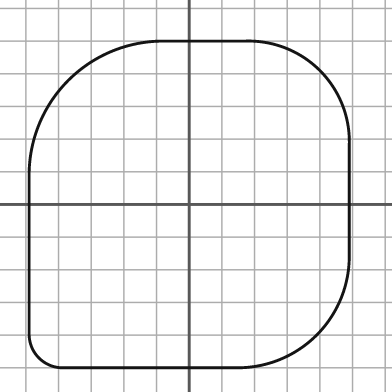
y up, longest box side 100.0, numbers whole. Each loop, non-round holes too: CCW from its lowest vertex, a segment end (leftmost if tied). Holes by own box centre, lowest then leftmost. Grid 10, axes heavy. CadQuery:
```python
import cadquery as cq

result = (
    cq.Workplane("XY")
    .moveTo(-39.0, -50.0)
    .lineTo(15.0, -50.0)
    .threePointArc((39.0, -40.0), (49.0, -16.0))
    .lineTo(49.0, 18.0)
    .threePointArc((40.0, 41.0), (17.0, 50.0))
    .lineTo(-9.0, 50.0)
    .threePointArc((-37.0, 38.0), (-49.0, 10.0))
    .lineTo(-49.0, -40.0)
    .threePointArc((-46.0, -47.0), (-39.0, -50.0))
    .close()
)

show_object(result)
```